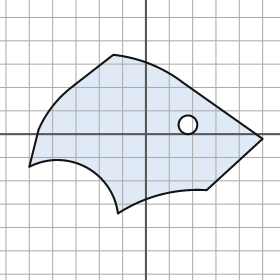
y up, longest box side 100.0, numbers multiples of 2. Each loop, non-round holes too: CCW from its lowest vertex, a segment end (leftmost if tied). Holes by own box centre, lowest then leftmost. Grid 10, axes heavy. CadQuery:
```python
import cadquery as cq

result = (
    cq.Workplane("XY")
    .moveTo(-12.0, -34.0)
    .threePointArc((6.0, -26.0), (26.0, -24.0))
    .lineTo(50.0, -2.0)
    .lineTo(16.0, 22.0)
    .threePointArc((2.0, 30.0), (-14.0, 34.0))
    .lineTo(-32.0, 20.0)
    .threePointArc((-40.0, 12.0), (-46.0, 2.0))
    .lineTo(-50.0, -14.0)
    .threePointArc((-26.0, -14.0), (-12.0, -34.0))
    .close()
    .moveTo(18.0, 4.0)
    .circle(4.0)
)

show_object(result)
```